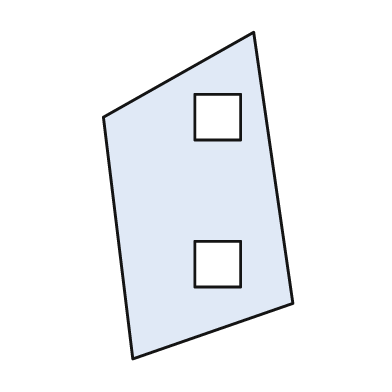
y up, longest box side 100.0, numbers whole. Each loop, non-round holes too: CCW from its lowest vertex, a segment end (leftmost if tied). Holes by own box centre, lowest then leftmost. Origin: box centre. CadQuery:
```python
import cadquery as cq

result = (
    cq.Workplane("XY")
    .moveTo(-20.0, -50.0)
    .lineTo(29.0, -33.0)
    .lineTo(17.0, 50.0)
    .lineTo(-29.0, 24.0)
    .close()
    .moveTo(-1.0, -28.0)
    .lineTo(13.0, -28.0)
    .lineTo(13.0, -14.0)
    .lineTo(-1.0, -14.0)
    .close()
    .moveTo(-1.0, 17.0)
    .lineTo(13.0, 17.0)
    .lineTo(13.0, 31.0)
    .lineTo(-1.0, 31.0)
    .close()
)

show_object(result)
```